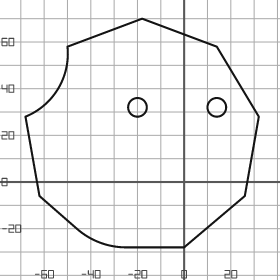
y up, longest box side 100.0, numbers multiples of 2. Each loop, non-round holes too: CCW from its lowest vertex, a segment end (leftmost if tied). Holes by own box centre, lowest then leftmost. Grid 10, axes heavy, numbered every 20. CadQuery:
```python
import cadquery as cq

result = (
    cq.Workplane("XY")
    .moveTo(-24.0, -28.0)
    .lineTo(0.0, -28.0)
    .lineTo(26.0, -6.0)
    .lineTo(32.0, 28.0)
    .lineTo(14.0, 58.0)
    .lineTo(-18.0, 70.0)
    .lineTo(-50.0, 58.0)
    .threePointArc((-54.0, 40.0), (-68.0, 28.0))
    .lineTo(-62.0, -6.0)
    .lineTo(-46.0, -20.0)
    .threePointArc((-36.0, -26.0), (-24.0, -28.0))
    .close()
    .moveTo(-20.0, 32.0)
    .circle(4.0)
    .moveTo(14.0, 32.0)
    .circle(4.0)
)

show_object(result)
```